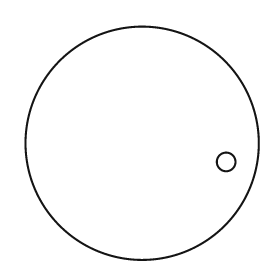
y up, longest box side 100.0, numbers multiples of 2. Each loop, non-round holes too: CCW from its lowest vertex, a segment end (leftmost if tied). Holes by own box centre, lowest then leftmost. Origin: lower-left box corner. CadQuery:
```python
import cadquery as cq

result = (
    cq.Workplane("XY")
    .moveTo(50.0, 50.0)
    .circle(50.0)
    .moveTo(86.0, 42.0)
    .circle(4.0)
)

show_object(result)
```